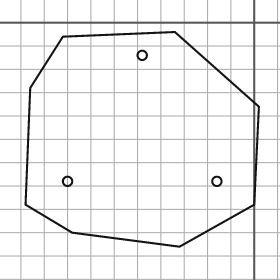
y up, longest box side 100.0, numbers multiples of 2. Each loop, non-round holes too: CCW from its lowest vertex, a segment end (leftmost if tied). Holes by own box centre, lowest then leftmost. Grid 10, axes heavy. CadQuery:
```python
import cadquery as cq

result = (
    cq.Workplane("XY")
    .moveTo(-32.0, -96.0)
    .lineTo(0.0, -78.0)
    .lineTo(2.0, -36.0)
    .lineTo(-34.0, -4.0)
    .lineTo(-82.0, -6.0)
    .lineTo(-96.0, -28.0)
    .lineTo(-98.0, -78.0)
    .lineTo(-78.0, -90.0)
    .close()
    .moveTo(-80.0, -68.0)
    .circle(2.0)
    .moveTo(-16.0, -68.0)
    .circle(2.0)
    .moveTo(-48.0, -14.0)
    .circle(2.0)
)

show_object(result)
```